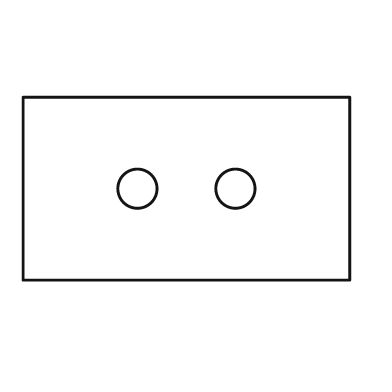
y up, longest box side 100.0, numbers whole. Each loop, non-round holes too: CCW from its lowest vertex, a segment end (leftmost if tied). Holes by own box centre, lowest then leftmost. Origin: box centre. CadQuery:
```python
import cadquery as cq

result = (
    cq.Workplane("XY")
    .moveTo(-50.0, -28.0)
    .lineTo(50.0, -28.0)
    .lineTo(50.0, 28.0)
    .lineTo(-50.0, 28.0)
    .close()
    .moveTo(-15.0, 0.0)
    .circle(6.0)
    .moveTo(15.0, 0.0)
    .circle(6.0)
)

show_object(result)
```